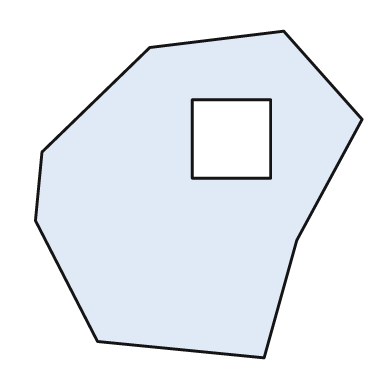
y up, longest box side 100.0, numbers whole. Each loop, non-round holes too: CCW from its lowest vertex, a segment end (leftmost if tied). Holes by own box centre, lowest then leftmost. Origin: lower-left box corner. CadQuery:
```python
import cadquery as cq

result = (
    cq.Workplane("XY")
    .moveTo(70.0, 0.0)
    .lineTo(80.0, 36.0)
    .lineTo(100.0, 73.0)
    .lineTo(76.0, 100.0)
    .lineTo(35.0, 95.0)
    .lineTo(2.0, 63.0)
    .lineTo(0.0, 42.0)
    .lineTo(19.0, 5.0)
    .close()
    .moveTo(48.0, 55.0)
    .lineTo(72.0, 55.0)
    .lineTo(72.0, 79.0)
    .lineTo(48.0, 79.0)
    .close()
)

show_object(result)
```